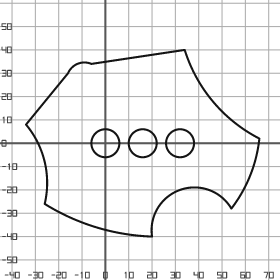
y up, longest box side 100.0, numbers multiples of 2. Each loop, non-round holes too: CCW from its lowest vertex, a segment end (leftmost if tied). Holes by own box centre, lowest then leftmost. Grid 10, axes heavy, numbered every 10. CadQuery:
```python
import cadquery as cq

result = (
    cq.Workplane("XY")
    .moveTo(20.0, -40.0)
    .threePointArc((32.0, -20.0), (54.0, -28.0))
    .threePointArc((62.0, -14.0), (66.0, 2.0))
    .threePointArc((46.0, 18.0), (34.0, 40.0))
    .lineTo(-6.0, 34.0)
    .threePointArc((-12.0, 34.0), (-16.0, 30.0))
    .lineTo(-34.0, 8.0)
    .threePointArc((-26.0, -8.0), (-26.0, -26.0))
    .threePointArc((-4.0, -36.0), (20.0, -40.0))
    .close()
    .moveTo(0.0, 0.0)
    .circle(6.0)
    .moveTo(16.0, 0.0)
    .circle(6.0)
    .moveTo(32.0, 0.0)
    .circle(6.0)
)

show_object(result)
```